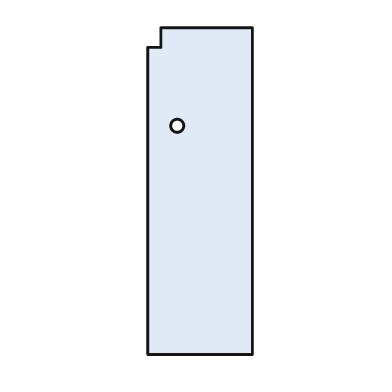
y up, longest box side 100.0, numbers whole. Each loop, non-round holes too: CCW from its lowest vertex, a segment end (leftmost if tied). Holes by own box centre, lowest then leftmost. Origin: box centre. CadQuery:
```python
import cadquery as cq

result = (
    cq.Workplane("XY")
    .moveTo(-16.0, -50.0)
    .lineTo(16.0, -50.0)
    .lineTo(16.0, 50.0)
    .lineTo(-12.0, 50.0)
    .lineTo(-12.0, 44.0)
    .lineTo(-16.0, 44.0)
    .close()
    .moveTo(-7.0, 20.0)
    .circle(2.0)
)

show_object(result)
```